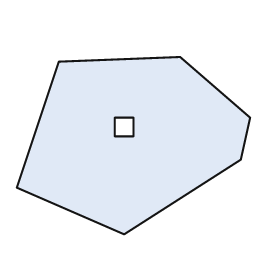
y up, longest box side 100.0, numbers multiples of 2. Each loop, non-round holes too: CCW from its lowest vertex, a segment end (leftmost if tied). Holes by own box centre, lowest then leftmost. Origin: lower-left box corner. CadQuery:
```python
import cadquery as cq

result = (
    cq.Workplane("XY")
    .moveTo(46.0, 0.0)
    .lineTo(96.0, 32.0)
    .lineTo(100.0, 50.0)
    .lineTo(70.0, 76.0)
    .lineTo(18.0, 74.0)
    .lineTo(0.0, 20.0)
    .close()
    .moveTo(42.0, 42.0)
    .lineTo(50.0, 42.0)
    .lineTo(50.0, 50.0)
    .lineTo(42.0, 50.0)
    .close()
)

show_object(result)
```